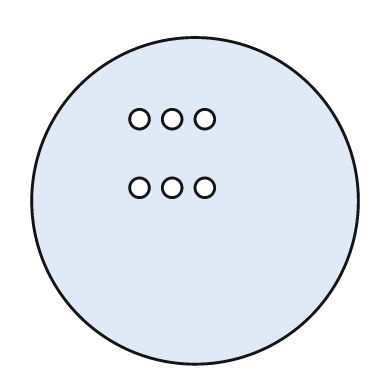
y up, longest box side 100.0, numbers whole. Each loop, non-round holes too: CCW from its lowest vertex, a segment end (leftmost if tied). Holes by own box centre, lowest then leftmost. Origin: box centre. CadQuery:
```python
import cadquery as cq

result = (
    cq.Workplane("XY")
    .moveTo(0.0, 0.0)
    .circle(50.0)
    .moveTo(-17.0, 4.0)
    .circle(3.0)
    .moveTo(-7.0, 4.0)
    .circle(3.0)
    .moveTo(3.0, 4.0)
    .circle(3.0)
    .moveTo(-17.0, 25.0)
    .circle(3.0)
    .moveTo(-7.0, 25.0)
    .circle(3.0)
    .moveTo(3.0, 25.0)
    .circle(3.0)
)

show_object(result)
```